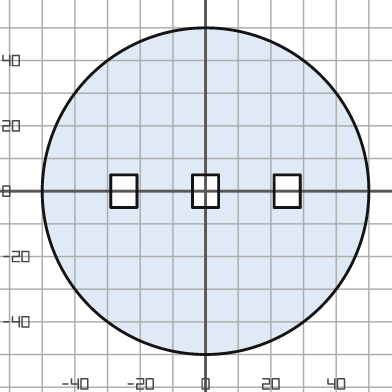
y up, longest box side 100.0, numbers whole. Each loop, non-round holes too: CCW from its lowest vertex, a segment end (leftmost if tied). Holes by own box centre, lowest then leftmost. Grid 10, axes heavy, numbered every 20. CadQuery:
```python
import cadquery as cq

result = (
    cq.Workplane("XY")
    .moveTo(0.0, 0.0)
    .circle(50.0)
    .moveTo(-29.0, -5.0)
    .lineTo(-21.0, -5.0)
    .lineTo(-21.0, 5.0)
    .lineTo(-29.0, 5.0)
    .close()
    .moveTo(-4.0, -5.0)
    .lineTo(4.0, -5.0)
    .lineTo(4.0, 5.0)
    .lineTo(-4.0, 5.0)
    .close()
    .moveTo(21.0, -5.0)
    .lineTo(29.0, -5.0)
    .lineTo(29.0, 5.0)
    .lineTo(21.0, 5.0)
    .close()
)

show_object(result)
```